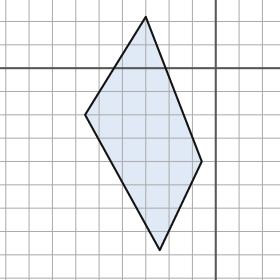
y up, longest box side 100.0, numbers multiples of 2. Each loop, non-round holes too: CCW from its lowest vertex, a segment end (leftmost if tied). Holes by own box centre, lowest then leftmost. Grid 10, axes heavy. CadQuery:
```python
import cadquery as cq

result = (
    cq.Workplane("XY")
    .moveTo(-24.0, -78.0)
    .lineTo(-6.0, -40.0)
    .lineTo(-30.0, 22.0)
    .lineTo(-56.0, -20.0)
    .close()
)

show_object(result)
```